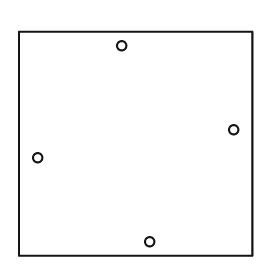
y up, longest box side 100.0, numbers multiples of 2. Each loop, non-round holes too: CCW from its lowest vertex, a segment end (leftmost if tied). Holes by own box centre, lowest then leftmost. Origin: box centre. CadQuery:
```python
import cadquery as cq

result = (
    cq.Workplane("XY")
    .moveTo(-50.0, -48.0)
    .lineTo(50.0, -48.0)
    .lineTo(50.0, 48.0)
    .lineTo(-50.0, 48.0)
    .close()
    .moveTo(6.0, -42.0)
    .circle(2.0)
    .moveTo(-42.0, -6.0)
    .circle(2.0)
    .moveTo(42.0, 6.0)
    .circle(2.0)
    .moveTo(-6.0, 42.0)
    .circle(2.0)
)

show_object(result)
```